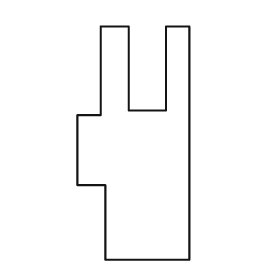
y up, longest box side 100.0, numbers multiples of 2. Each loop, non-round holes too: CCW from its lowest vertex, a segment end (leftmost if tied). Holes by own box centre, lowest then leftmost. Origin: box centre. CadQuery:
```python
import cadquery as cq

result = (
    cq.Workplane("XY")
    .moveTo(-12.0, -50.0)
    .lineTo(24.0, -50.0)
    .lineTo(24.0, 50.0)
    .lineTo(14.0, 50.0)
    .lineTo(14.0, 14.0)
    .lineTo(-2.0, 14.0)
    .lineTo(-2.0, 50.0)
    .lineTo(-14.0, 50.0)
    .lineTo(-14.0, 12.0)
    .lineTo(-24.0, 12.0)
    .lineTo(-24.0, -18.0)
    .lineTo(-12.0, -18.0)
    .close()
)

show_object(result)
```